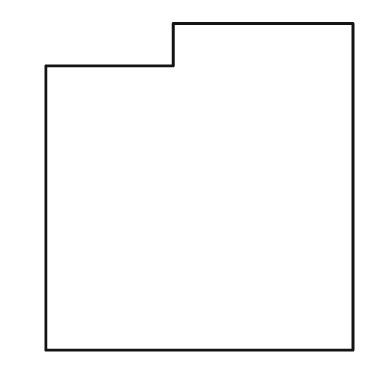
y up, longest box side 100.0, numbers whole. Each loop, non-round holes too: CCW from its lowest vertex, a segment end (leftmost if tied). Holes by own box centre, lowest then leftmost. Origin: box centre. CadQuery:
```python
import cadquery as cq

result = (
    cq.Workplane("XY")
    .moveTo(-47.0, -50.0)
    .lineTo(47.0, -50.0)
    .lineTo(47.0, 50.0)
    .lineTo(-8.0, 50.0)
    .lineTo(-8.0, 37.0)
    .lineTo(-47.0, 37.0)
    .close()
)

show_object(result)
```